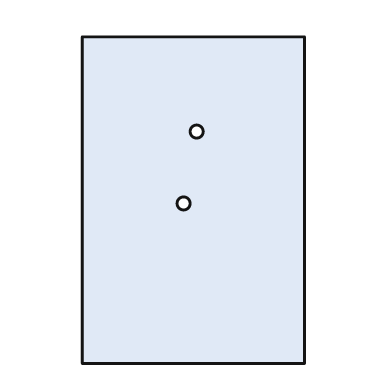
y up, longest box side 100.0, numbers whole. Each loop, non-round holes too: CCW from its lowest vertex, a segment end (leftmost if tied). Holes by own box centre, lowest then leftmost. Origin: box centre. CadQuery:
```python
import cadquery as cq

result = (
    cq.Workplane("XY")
    .moveTo(-34.0, -50.0)
    .lineTo(34.0, -50.0)
    .lineTo(34.0, 50.0)
    .lineTo(-34.0, 50.0)
    .close()
    .moveTo(-3.0, -1.0)
    .circle(2.0)
    .moveTo(1.0, 21.0)
    .circle(2.0)
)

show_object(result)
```